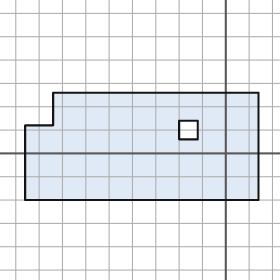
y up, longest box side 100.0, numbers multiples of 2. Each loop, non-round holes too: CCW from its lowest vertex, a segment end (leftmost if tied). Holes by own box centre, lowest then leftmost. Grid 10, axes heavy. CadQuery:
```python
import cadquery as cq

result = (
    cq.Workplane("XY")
    .moveTo(-86.0, -20.0)
    .lineTo(14.0, -20.0)
    .lineTo(14.0, 26.0)
    .lineTo(-74.0, 26.0)
    .lineTo(-74.0, 12.0)
    .lineTo(-86.0, 12.0)
    .close()
    .moveTo(-20.0, 6.0)
    .lineTo(-12.0, 6.0)
    .lineTo(-12.0, 14.0)
    .lineTo(-20.0, 14.0)
    .close()
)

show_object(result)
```